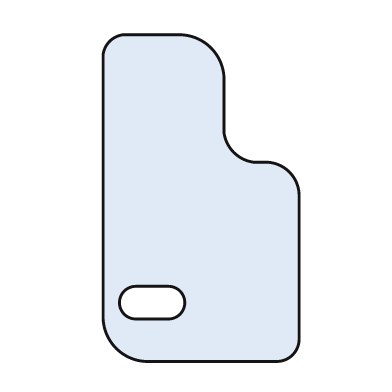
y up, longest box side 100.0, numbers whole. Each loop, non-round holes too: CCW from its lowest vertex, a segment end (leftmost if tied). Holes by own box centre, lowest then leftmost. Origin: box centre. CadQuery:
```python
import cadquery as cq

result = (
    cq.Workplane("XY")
    .moveTo(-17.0, -50.0)
    .lineTo(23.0, -50.0)
    .threePointArc((28.0, -48.0), (30.0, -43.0))
    .lineTo(30.0, 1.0)
    .threePointArc((27.0, 8.0), (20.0, 11.0))
    .lineTo(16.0, 11.0)
    .threePointArc((10.0, 14.0), (7.0, 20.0))
    .lineTo(7.0, 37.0)
    .threePointArc((3.0, 46.0), (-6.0, 50.0))
    .lineTo(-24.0, 50.0)
    .threePointArc((-28.0, 48.0), (-30.0, 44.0))
    .lineTo(-30.0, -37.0)
    .threePointArc((-26.0, -46.0), (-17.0, -50.0))
    .close()
    .moveTo(-20.0, -37.0)
    .lineTo(-10.0, -37.0)
    .threePointArc((-5.0, -32.0), (-10.0, -27.0))
    .lineTo(-20.0, -27.0)
    .threePointArc((-25.0, -32.0), (-20.0, -37.0))
    .close()
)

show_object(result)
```